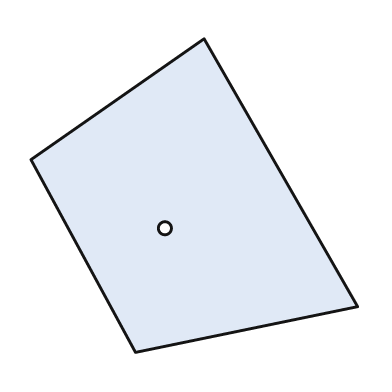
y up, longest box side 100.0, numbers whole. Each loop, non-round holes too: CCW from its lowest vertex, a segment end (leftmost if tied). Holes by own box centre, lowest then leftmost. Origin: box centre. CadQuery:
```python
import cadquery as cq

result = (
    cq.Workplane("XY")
    .moveTo(-18.0, -48.0)
    .lineTo(50.0, -34.0)
    .lineTo(3.0, 48.0)
    .lineTo(-50.0, 11.0)
    .close()
    .moveTo(-9.0, -10.0)
    .circle(2.0)
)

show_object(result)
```